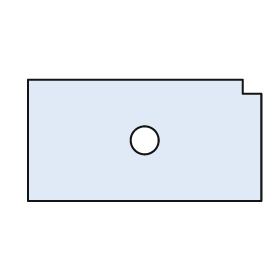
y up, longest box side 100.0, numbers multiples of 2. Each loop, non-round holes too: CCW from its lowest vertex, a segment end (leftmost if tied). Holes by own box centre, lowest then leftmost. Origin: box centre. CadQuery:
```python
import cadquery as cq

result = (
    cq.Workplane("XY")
    .moveTo(-50.0, -26.0)
    .lineTo(50.0, -26.0)
    .lineTo(50.0, 20.0)
    .lineTo(42.0, 20.0)
    .lineTo(42.0, 26.0)
    .lineTo(-50.0, 26.0)
    .close()
    .moveTo(0.0, 0.0)
    .circle(6.0)
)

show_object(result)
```